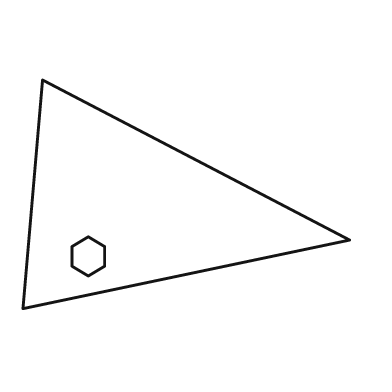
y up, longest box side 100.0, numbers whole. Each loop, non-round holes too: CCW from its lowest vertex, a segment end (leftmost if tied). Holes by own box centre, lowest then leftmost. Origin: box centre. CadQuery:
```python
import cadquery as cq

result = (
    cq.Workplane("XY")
    .moveTo(-50.0, -35.0)
    .lineTo(50.0, -14.0)
    .lineTo(-44.0, 35.0)
    .close()
    .moveTo(-30.0, -25.0)
    .lineTo(-25.0, -22.0)
    .lineTo(-25.0, -16.0)
    .lineTo(-30.0, -13.0)
    .lineTo(-35.0, -16.0)
    .lineTo(-35.0, -22.0)
    .close()
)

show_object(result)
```